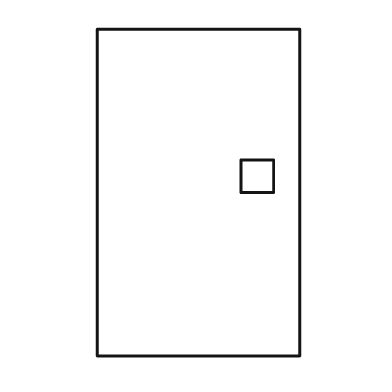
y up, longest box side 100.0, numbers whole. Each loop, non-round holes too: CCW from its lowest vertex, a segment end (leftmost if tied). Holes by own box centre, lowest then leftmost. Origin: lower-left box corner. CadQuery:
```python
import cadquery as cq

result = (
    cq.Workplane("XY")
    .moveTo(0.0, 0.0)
    .lineTo(62.0, 0.0)
    .lineTo(62.0, 100.0)
    .lineTo(0.0, 100.0)
    .close()
    .moveTo(44.0, 50.0)
    .lineTo(54.0, 50.0)
    .lineTo(54.0, 60.0)
    .lineTo(44.0, 60.0)
    .close()
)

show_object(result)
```